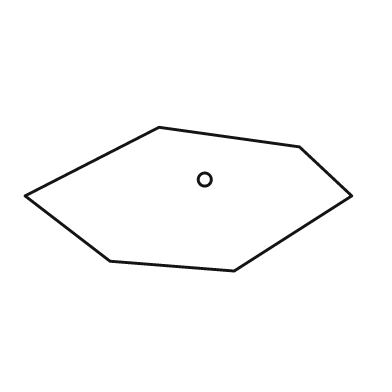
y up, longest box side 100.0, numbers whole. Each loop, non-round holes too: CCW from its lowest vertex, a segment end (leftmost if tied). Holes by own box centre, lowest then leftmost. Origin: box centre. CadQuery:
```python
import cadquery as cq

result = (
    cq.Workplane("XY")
    .moveTo(14.0, -22.0)
    .lineTo(50.0, 1.0)
    .lineTo(34.0, 16.0)
    .lineTo(-9.0, 22.0)
    .lineTo(-50.0, 1.0)
    .lineTo(-24.0, -19.0)
    .close()
    .moveTo(5.0, 6.0)
    .circle(2.0)
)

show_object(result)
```